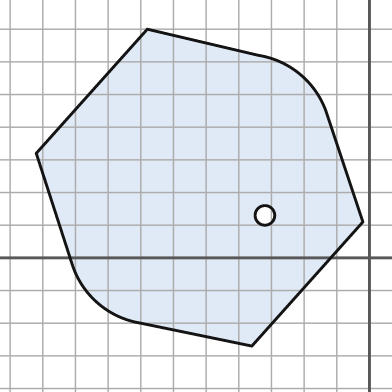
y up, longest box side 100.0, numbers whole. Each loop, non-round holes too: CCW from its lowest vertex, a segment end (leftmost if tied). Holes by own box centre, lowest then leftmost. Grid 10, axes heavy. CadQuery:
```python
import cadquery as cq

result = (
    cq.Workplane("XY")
    .moveTo(-36.0, -27.0)
    .lineTo(-2.0, 11.0)
    .lineTo(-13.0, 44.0)
    .threePointArc((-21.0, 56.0), (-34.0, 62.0))
    .lineTo(-68.0, 70.0)
    .lineTo(-102.0, 32.0)
    .lineTo(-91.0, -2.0)
    .threePointArc((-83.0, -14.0), (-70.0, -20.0))
    .close()
    .moveTo(-32.0, 13.0)
    .circle(3.0)
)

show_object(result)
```